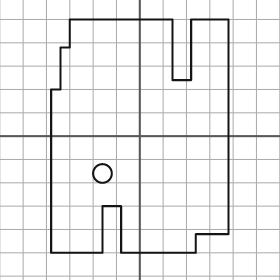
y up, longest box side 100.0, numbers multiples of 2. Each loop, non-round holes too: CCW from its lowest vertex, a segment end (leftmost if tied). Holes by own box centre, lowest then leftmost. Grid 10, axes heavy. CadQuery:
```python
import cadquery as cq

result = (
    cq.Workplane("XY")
    .moveTo(-38.0, -50.0)
    .lineTo(-16.0, -50.0)
    .lineTo(-16.0, -30.0)
    .lineTo(-8.0, -30.0)
    .lineTo(-8.0, -50.0)
    .lineTo(24.0, -50.0)
    .lineTo(24.0, -42.0)
    .lineTo(38.0, -42.0)
    .lineTo(38.0, 50.0)
    .lineTo(22.0, 50.0)
    .lineTo(22.0, 24.0)
    .lineTo(14.0, 24.0)
    .lineTo(14.0, 50.0)
    .lineTo(-30.0, 50.0)
    .lineTo(-30.0, 38.0)
    .lineTo(-34.0, 38.0)
    .lineTo(-34.0, 20.0)
    .lineTo(-38.0, 20.0)
    .close()
    .moveTo(-16.0, -16.0)
    .circle(4.0)
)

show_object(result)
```